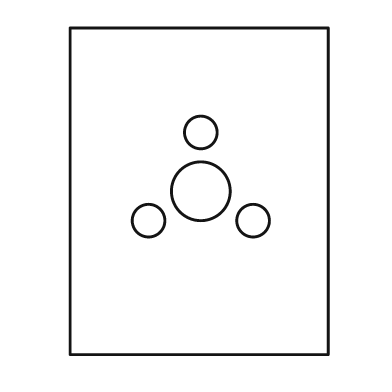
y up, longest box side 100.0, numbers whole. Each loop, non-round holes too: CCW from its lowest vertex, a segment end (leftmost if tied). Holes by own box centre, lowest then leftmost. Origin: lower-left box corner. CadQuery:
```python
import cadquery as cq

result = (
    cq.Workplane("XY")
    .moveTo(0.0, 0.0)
    .lineTo(79.0, 0.0)
    .lineTo(79.0, 100.0)
    .lineTo(0.0, 100.0)
    .close()
    .moveTo(24.0, 41.0)
    .circle(5.0)
    .moveTo(56.0, 41.0)
    .circle(5.0)
    .moveTo(40.0, 50.0)
    .circle(9.0)
    .moveTo(40.0, 68.0)
    .circle(5.0)
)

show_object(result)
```